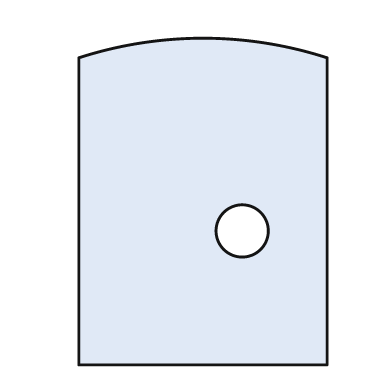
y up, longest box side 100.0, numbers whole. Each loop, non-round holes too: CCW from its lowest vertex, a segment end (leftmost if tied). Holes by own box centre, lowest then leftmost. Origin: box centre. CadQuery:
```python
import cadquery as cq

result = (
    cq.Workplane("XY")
    .moveTo(-38.0, -50.0)
    .lineTo(38.0, -50.0)
    .lineTo(38.0, 44.0)
    .threePointArc((0.0, 50.0), (-38.0, 44.0))
    .close()
    .moveTo(12.0, -9.0)
    .circle(8.0)
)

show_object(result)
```